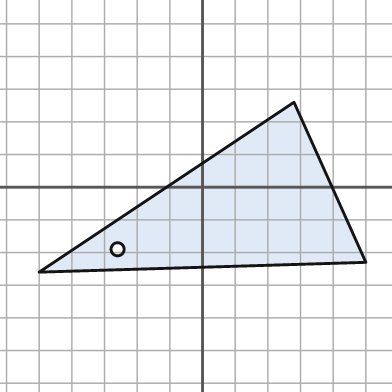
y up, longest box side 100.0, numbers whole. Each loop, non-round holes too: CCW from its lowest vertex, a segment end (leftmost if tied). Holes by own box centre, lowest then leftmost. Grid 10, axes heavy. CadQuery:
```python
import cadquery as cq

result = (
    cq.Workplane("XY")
    .moveTo(-50.0, -26.0)
    .lineTo(50.0, -23.0)
    .lineTo(28.0, 26.0)
    .close()
    .moveTo(-26.0, -19.0)
    .circle(2.0)
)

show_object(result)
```